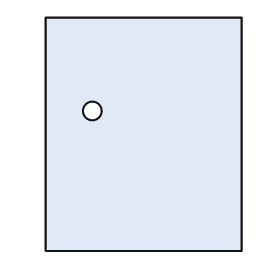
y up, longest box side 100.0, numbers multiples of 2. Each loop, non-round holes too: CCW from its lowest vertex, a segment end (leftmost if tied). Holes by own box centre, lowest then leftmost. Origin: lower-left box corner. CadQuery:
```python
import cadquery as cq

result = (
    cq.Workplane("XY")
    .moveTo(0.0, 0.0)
    .lineTo(84.0, 0.0)
    .lineTo(84.0, 100.0)
    .lineTo(0.0, 100.0)
    .close()
    .moveTo(20.0, 60.0)
    .circle(4.0)
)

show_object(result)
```